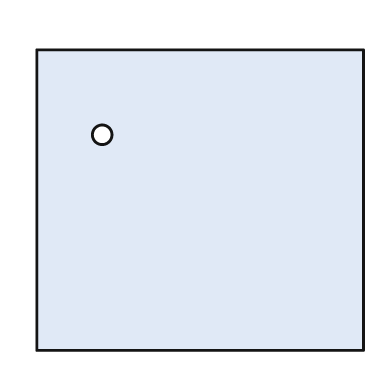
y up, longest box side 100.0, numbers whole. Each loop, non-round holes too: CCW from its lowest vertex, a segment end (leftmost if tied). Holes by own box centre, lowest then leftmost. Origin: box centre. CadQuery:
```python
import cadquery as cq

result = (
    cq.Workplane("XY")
    .moveTo(-50.0, -46.0)
    .lineTo(50.0, -46.0)
    .lineTo(50.0, 46.0)
    .lineTo(-50.0, 46.0)
    .close()
    .moveTo(-30.0, 20.0)
    .circle(3.0)
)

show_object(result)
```